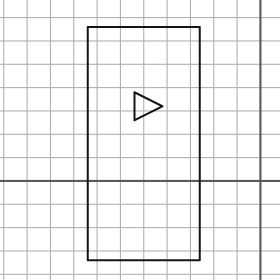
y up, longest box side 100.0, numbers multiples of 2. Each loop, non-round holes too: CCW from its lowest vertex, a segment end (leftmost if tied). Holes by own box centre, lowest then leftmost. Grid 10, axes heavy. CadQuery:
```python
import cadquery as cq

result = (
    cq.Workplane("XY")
    .moveTo(-74.0, -34.0)
    .lineTo(-26.0, -34.0)
    .lineTo(-26.0, 66.0)
    .lineTo(-74.0, 66.0)
    .close()
    .moveTo(-54.0, 26.0)
    .lineTo(-42.0, 32.0)
    .lineTo(-54.0, 38.0)
    .close()
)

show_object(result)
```